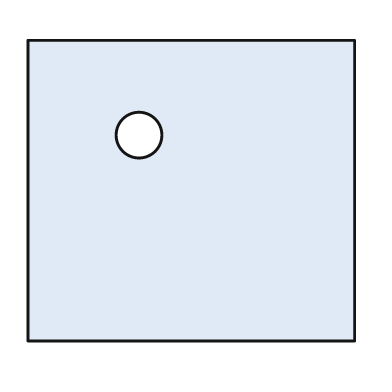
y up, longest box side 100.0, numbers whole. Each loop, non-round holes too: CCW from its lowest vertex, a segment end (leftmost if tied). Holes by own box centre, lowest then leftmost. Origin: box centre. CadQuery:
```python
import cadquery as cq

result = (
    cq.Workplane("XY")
    .moveTo(-50.0, -46.0)
    .lineTo(50.0, -46.0)
    .lineTo(50.0, 46.0)
    .lineTo(-50.0, 46.0)
    .close()
    .moveTo(-16.0, 17.0)
    .circle(7.0)
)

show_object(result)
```